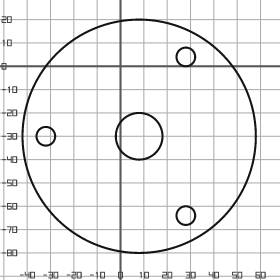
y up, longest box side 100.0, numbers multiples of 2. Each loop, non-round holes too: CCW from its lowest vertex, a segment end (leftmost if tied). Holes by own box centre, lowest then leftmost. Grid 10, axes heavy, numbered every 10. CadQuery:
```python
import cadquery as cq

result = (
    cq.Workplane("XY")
    .moveTo(8.0, -30.0)
    .circle(50.0)
    .moveTo(28.0, -64.0)
    .circle(4.0)
    .moveTo(-32.0, -30.0)
    .circle(4.0)
    .moveTo(8.0, -30.0)
    .circle(10.0)
    .moveTo(28.0, 4.0)
    .circle(4.0)
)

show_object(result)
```